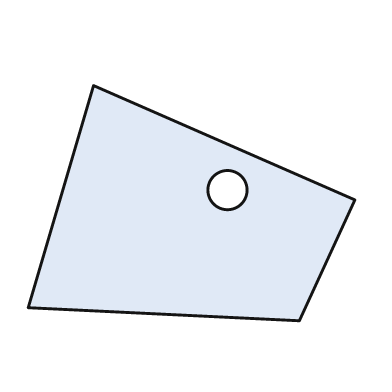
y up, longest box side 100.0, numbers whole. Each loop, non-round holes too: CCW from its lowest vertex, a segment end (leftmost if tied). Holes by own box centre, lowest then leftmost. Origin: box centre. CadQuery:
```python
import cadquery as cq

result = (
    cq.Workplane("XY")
    .moveTo(33.0, -36.0)
    .lineTo(50.0, 1.0)
    .lineTo(-30.0, 36.0)
    .lineTo(-50.0, -32.0)
    .close()
    .moveTo(11.0, 4.0)
    .circle(6.0)
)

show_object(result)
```